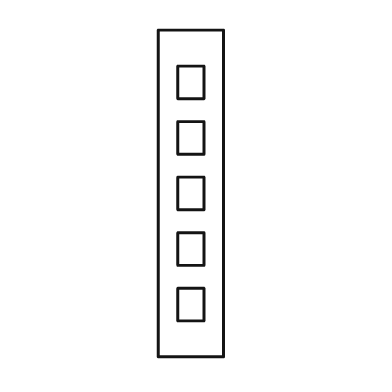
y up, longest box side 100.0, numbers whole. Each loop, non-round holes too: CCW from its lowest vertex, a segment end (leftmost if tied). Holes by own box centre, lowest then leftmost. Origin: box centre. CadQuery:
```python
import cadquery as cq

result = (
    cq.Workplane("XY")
    .moveTo(-10.0, -50.0)
    .lineTo(10.0, -50.0)
    .lineTo(10.0, 50.0)
    .lineTo(-10.0, 50.0)
    .close()
    .moveTo(-4.0, -39.0)
    .lineTo(4.0, -39.0)
    .lineTo(4.0, -29.0)
    .lineTo(-4.0, -29.0)
    .close()
    .moveTo(-4.0, -22.0)
    .lineTo(4.0, -22.0)
    .lineTo(4.0, -12.0)
    .lineTo(-4.0, -12.0)
    .close()
    .moveTo(-4.0, -5.0)
    .lineTo(4.0, -5.0)
    .lineTo(4.0, 5.0)
    .lineTo(-4.0, 5.0)
    .close()
    .moveTo(-4.0, 12.0)
    .lineTo(4.0, 12.0)
    .lineTo(4.0, 22.0)
    .lineTo(-4.0, 22.0)
    .close()
    .moveTo(-4.0, 29.0)
    .lineTo(4.0, 29.0)
    .lineTo(4.0, 39.0)
    .lineTo(-4.0, 39.0)
    .close()
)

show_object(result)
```